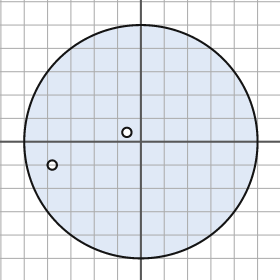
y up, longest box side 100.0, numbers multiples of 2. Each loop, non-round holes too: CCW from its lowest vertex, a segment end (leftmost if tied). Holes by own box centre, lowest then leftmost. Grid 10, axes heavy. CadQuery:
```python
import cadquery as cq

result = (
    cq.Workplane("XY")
    .moveTo(0.0, 0.0)
    .circle(50.0)
    .moveTo(-38.0, -10.0)
    .circle(2.0)
    .moveTo(-6.0, 4.0)
    .circle(2.0)
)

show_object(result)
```